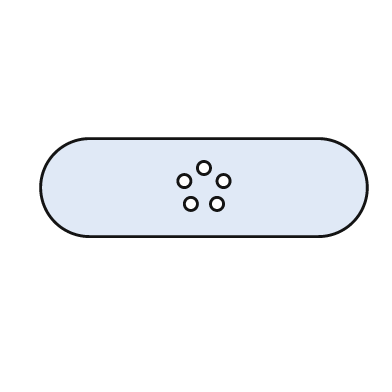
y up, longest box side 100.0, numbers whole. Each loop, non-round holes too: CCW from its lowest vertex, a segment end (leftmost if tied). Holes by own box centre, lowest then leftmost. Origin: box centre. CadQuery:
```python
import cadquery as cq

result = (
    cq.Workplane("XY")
    .moveTo(-35.0, -15.0)
    .lineTo(35.0, -15.0)
    .threePointArc((50.0, 0.0), (35.0, 15.0))
    .lineTo(-35.0, 15.0)
    .threePointArc((-50.0, 0.0), (-35.0, -15.0))
    .close()
    .moveTo(-4.0, -5.0)
    .circle(2.0)
    .moveTo(4.0, -5.0)
    .circle(2.0)
    .moveTo(-6.0, 2.0)
    .circle(2.0)
    .moveTo(6.0, 2.0)
    .circle(2.0)
    .moveTo(0.0, 6.0)
    .circle(2.0)
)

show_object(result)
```